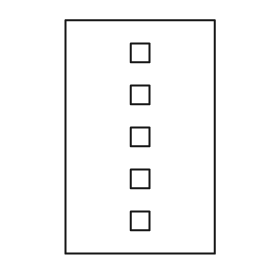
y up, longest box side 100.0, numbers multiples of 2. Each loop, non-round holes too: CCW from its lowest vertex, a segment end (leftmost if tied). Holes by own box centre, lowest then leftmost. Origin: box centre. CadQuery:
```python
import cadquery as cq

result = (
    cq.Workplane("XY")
    .moveTo(-32.0, -50.0)
    .lineTo(32.0, -50.0)
    .lineTo(32.0, 50.0)
    .lineTo(-32.0, 50.0)
    .close()
    .moveTo(-4.0, -40.0)
    .lineTo(4.0, -40.0)
    .lineTo(4.0, -32.0)
    .lineTo(-4.0, -32.0)
    .close()
    .moveTo(-4.0, -22.0)
    .lineTo(4.0, -22.0)
    .lineTo(4.0, -14.0)
    .lineTo(-4.0, -14.0)
    .close()
    .moveTo(-4.0, -4.0)
    .lineTo(4.0, -4.0)
    .lineTo(4.0, 4.0)
    .lineTo(-4.0, 4.0)
    .close()
    .moveTo(-4.0, 14.0)
    .lineTo(4.0, 14.0)
    .lineTo(4.0, 22.0)
    .lineTo(-4.0, 22.0)
    .close()
    .moveTo(-4.0, 32.0)
    .lineTo(4.0, 32.0)
    .lineTo(4.0, 40.0)
    .lineTo(-4.0, 40.0)
    .close()
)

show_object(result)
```